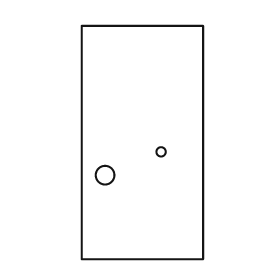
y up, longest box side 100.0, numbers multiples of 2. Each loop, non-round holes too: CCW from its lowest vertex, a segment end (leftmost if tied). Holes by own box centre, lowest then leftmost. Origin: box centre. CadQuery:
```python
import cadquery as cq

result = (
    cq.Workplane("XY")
    .moveTo(-26.0, -50.0)
    .lineTo(26.0, -50.0)
    .lineTo(26.0, 50.0)
    .lineTo(-26.0, 50.0)
    .close()
    .moveTo(-16.0, -14.0)
    .circle(4.0)
    .moveTo(8.0, -4.0)
    .circle(2.0)
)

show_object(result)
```